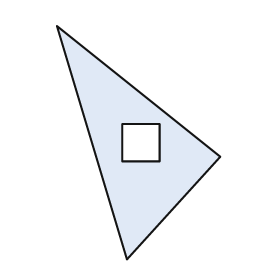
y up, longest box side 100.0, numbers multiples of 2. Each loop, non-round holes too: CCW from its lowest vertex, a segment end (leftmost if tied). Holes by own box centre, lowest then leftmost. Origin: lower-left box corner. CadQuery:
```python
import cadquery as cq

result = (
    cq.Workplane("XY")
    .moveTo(30.0, 0.0)
    .lineTo(70.0, 44.0)
    .lineTo(0.0, 100.0)
    .close()
    .moveTo(28.0, 42.0)
    .lineTo(44.0, 42.0)
    .lineTo(44.0, 58.0)
    .lineTo(28.0, 58.0)
    .close()
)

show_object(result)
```